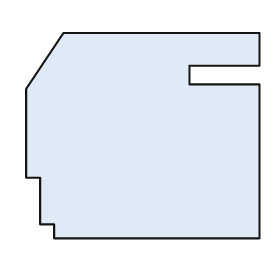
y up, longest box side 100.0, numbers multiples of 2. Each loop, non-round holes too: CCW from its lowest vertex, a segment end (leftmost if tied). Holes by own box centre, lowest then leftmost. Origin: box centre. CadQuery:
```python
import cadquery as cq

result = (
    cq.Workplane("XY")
    .moveTo(-38.0, -44.0)
    .lineTo(50.0, -44.0)
    .lineTo(50.0, 22.0)
    .lineTo(20.0, 22.0)
    .lineTo(20.0, 30.0)
    .lineTo(50.0, 30.0)
    .lineTo(50.0, 44.0)
    .lineTo(-34.0, 44.0)
    .lineTo(-50.0, 20.0)
    .lineTo(-50.0, -18.0)
    .lineTo(-44.0, -18.0)
    .lineTo(-44.0, -38.0)
    .lineTo(-38.0, -38.0)
    .close()
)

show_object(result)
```